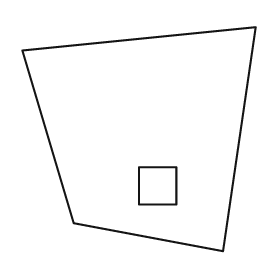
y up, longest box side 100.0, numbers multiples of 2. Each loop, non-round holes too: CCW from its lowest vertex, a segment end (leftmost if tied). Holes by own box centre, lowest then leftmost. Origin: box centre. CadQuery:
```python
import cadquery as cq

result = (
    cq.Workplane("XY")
    .moveTo(36.0, -48.0)
    .lineTo(50.0, 48.0)
    .lineTo(-50.0, 38.0)
    .lineTo(-28.0, -36.0)
    .close()
    .moveTo(0.0, -28.0)
    .lineTo(16.0, -28.0)
    .lineTo(16.0, -12.0)
    .lineTo(0.0, -12.0)
    .close()
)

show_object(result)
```